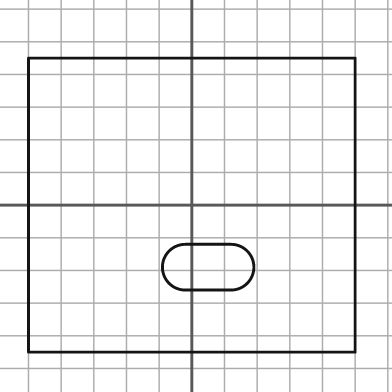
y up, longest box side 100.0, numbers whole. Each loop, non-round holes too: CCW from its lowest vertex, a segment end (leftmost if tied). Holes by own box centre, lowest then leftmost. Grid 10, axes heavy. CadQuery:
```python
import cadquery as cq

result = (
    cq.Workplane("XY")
    .moveTo(-50.0, -45.0)
    .lineTo(50.0, -45.0)
    .lineTo(50.0, 45.0)
    .lineTo(-50.0, 45.0)
    .close()
    .moveTo(-2.0, -26.0)
    .lineTo(12.0, -26.0)
    .threePointArc((19.0, -19.0), (12.0, -12.0))
    .lineTo(-2.0, -12.0)
    .threePointArc((-9.0, -19.0), (-2.0, -26.0))
    .close()
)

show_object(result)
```